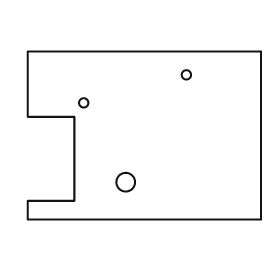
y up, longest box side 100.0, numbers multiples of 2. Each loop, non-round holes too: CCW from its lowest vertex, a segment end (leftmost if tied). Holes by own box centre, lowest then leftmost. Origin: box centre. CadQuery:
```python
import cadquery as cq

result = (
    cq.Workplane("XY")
    .moveTo(-50.0, -36.0)
    .lineTo(50.0, -36.0)
    .lineTo(50.0, 36.0)
    .lineTo(-50.0, 36.0)
    .lineTo(-50.0, 8.0)
    .lineTo(-30.0, 8.0)
    .lineTo(-30.0, -28.0)
    .lineTo(-50.0, -28.0)
    .close()
    .moveTo(-8.0, -20.0)
    .circle(4.0)
    .moveTo(-26.0, 14.0)
    .circle(2.0)
    .moveTo(18.0, 26.0)
    .circle(2.0)
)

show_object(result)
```